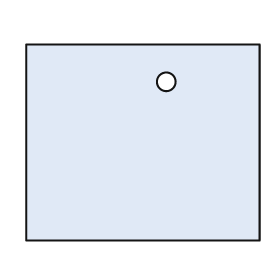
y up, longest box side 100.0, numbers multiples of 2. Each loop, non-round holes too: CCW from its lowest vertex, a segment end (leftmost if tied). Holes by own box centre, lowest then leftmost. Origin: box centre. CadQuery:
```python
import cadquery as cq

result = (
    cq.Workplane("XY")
    .moveTo(-50.0, -42.0)
    .lineTo(50.0, -42.0)
    .lineTo(50.0, 42.0)
    .lineTo(-50.0, 42.0)
    .close()
    .moveTo(10.0, 26.0)
    .circle(4.0)
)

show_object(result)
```